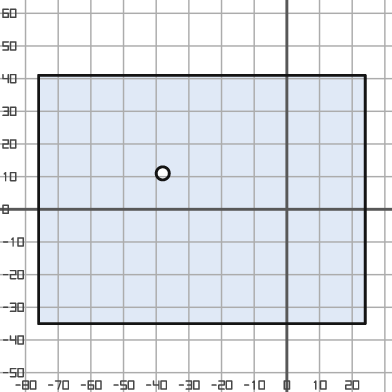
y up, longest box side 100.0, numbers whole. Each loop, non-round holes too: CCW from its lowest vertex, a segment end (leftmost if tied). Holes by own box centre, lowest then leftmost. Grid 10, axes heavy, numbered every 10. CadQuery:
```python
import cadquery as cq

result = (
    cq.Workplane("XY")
    .moveTo(-76.0, -35.0)
    .lineTo(24.0, -35.0)
    .lineTo(24.0, 41.0)
    .lineTo(-76.0, 41.0)
    .close()
    .moveTo(-38.0, 11.0)
    .circle(2.0)
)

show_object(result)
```